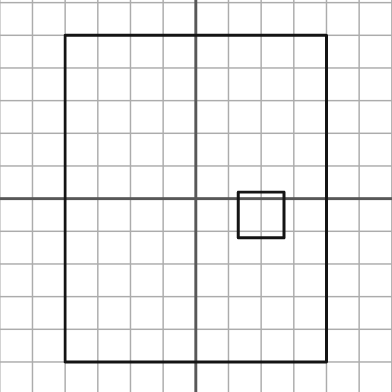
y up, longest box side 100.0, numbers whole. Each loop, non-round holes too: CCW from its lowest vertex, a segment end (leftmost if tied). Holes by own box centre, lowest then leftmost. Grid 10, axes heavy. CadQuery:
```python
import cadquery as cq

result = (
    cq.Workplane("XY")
    .moveTo(-40.0, -50.0)
    .lineTo(40.0, -50.0)
    .lineTo(40.0, 50.0)
    .lineTo(-40.0, 50.0)
    .close()
    .moveTo(13.0, -12.0)
    .lineTo(27.0, -12.0)
    .lineTo(27.0, 2.0)
    .lineTo(13.0, 2.0)
    .close()
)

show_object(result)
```